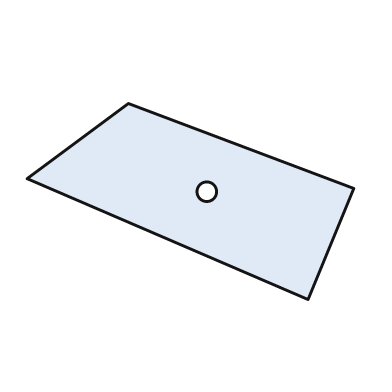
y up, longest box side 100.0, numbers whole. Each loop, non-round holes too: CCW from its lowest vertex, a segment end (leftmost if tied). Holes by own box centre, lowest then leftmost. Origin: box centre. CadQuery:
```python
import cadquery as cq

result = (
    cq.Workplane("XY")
    .moveTo(36.0, -30.0)
    .lineTo(50.0, 4.0)
    .lineTo(-19.0, 30.0)
    .lineTo(-50.0, 7.0)
    .close()
    .moveTo(5.0, 3.0)
    .circle(3.0)
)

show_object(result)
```